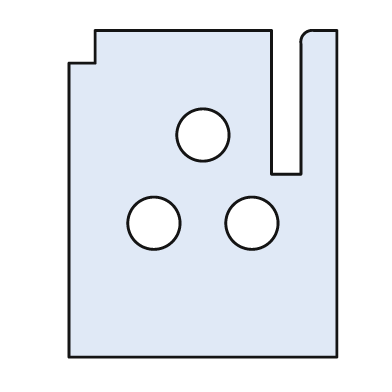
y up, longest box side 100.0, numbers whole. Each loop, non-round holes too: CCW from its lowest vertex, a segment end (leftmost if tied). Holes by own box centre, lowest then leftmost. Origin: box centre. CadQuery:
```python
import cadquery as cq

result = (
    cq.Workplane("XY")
    .moveTo(-41.0, -50.0)
    .lineTo(41.0, -50.0)
    .lineTo(41.0, 50.0)
    .lineTo(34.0, 50.0)
    .threePointArc((31.0, 49.0), (30.0, 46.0))
    .lineTo(30.0, 6.0)
    .lineTo(21.0, 6.0)
    .lineTo(21.0, 50.0)
    .lineTo(-33.0, 50.0)
    .lineTo(-33.0, 40.0)
    .lineTo(-41.0, 40.0)
    .close()
    .moveTo(-15.0, -9.0)
    .circle(8.0)
    .moveTo(15.0, -9.0)
    .circle(8.0)
    .moveTo(0.0, 18.0)
    .circle(8.0)
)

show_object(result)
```